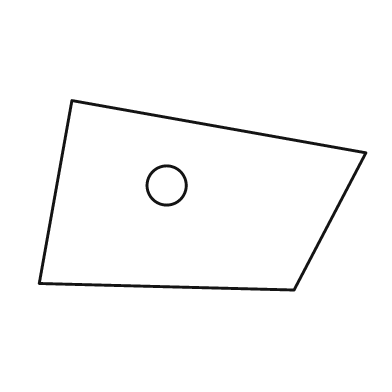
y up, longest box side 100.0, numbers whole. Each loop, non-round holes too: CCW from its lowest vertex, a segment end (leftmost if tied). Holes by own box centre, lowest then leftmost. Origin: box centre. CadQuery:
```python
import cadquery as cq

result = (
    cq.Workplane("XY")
    .moveTo(28.0, -29.0)
    .lineTo(50.0, 13.0)
    .lineTo(-40.0, 29.0)
    .lineTo(-50.0, -27.0)
    .close()
    .moveTo(-11.0, 3.0)
    .circle(6.0)
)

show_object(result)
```